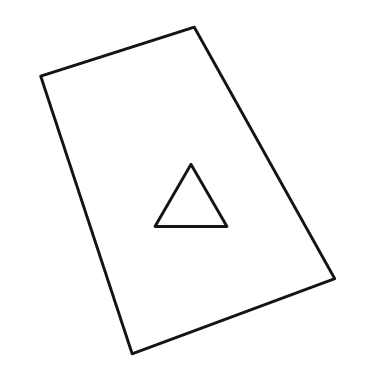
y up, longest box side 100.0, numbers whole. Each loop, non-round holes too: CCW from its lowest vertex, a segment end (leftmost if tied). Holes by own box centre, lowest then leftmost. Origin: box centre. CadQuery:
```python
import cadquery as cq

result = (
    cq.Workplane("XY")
    .moveTo(-17.0, -50.0)
    .lineTo(45.0, -27.0)
    .lineTo(2.0, 50.0)
    .lineTo(-45.0, 35.0)
    .close()
    .moveTo(-10.0, -11.0)
    .lineTo(12.0, -11.0)
    .lineTo(1.0, 8.0)
    .close()
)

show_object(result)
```